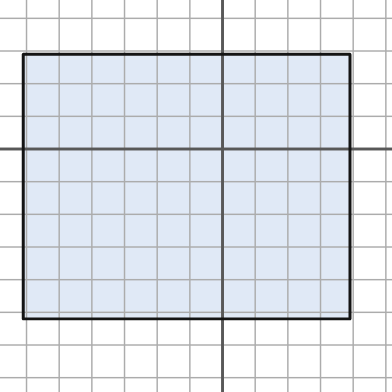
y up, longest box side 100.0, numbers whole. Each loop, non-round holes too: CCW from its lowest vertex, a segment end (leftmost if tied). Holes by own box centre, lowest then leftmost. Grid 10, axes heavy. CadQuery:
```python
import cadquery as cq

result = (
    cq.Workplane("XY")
    .moveTo(-61.0, -52.0)
    .lineTo(39.0, -52.0)
    .lineTo(39.0, 29.0)
    .lineTo(-61.0, 29.0)
    .close()
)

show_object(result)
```